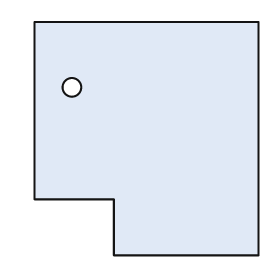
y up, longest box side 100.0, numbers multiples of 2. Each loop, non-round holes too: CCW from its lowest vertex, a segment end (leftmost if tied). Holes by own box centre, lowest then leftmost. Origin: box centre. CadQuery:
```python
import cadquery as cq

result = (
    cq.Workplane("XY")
    .moveTo(-14.0, -50.0)
    .lineTo(48.0, -50.0)
    .lineTo(48.0, 50.0)
    .lineTo(-48.0, 50.0)
    .lineTo(-48.0, -26.0)
    .lineTo(-14.0, -26.0)
    .close()
    .moveTo(-32.0, 22.0)
    .circle(4.0)
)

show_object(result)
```